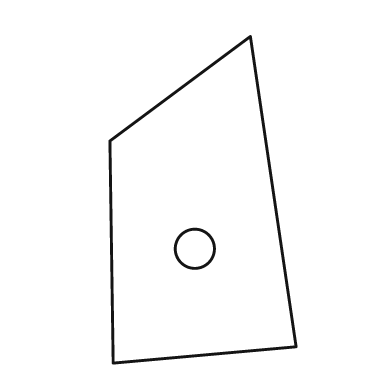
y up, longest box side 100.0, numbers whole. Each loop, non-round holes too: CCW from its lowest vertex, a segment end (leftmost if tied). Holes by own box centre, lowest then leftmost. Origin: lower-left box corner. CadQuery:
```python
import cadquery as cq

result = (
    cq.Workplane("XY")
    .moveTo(1.0, 0.0)
    .lineTo(57.0, 5.0)
    .lineTo(43.0, 100.0)
    .lineTo(0.0, 68.0)
    .close()
    .moveTo(26.0, 35.0)
    .circle(6.0)
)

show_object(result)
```